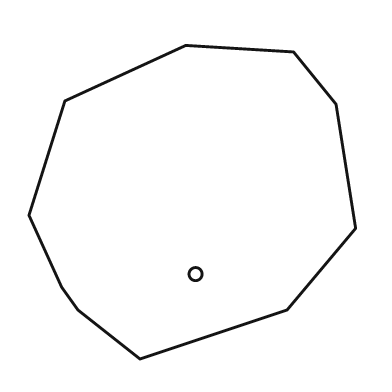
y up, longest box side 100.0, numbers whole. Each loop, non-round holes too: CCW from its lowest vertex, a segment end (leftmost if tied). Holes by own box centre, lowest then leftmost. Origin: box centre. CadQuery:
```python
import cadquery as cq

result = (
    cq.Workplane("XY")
    .moveTo(-16.0, -48.0)
    .lineTo(29.0, -33.0)
    .lineTo(50.0, -8.0)
    .lineTo(44.0, 30.0)
    .lineTo(31.0, 46.0)
    .lineTo(-2.0, 48.0)
    .lineTo(-39.0, 31.0)
    .lineTo(-50.0, -4.0)
    .lineTo(-40.0, -26.0)
    .lineTo(-35.0, -33.0)
    .close()
    .moveTo(1.0, -22.0)
    .circle(2.0)
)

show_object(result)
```